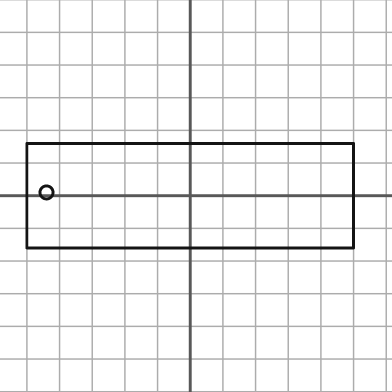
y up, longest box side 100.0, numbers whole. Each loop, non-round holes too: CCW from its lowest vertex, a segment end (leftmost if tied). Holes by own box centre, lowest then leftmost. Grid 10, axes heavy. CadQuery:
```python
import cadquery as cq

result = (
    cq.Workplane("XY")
    .moveTo(-50.0, -16.0)
    .lineTo(50.0, -16.0)
    .lineTo(50.0, 16.0)
    .lineTo(-50.0, 16.0)
    .close()
    .moveTo(-44.0, 1.0)
    .circle(2.0)
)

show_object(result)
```